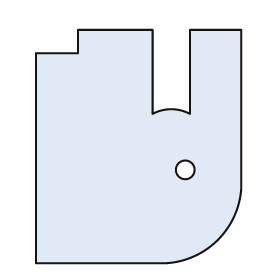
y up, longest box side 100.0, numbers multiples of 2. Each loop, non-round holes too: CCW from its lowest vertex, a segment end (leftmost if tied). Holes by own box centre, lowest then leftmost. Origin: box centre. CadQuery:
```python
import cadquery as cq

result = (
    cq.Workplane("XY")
    .moveTo(-44.0, -50.0)
    .lineTo(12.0, -50.0)
    .threePointArc((34.0, -40.0), (44.0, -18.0))
    .lineTo(44.0, 50.0)
    .lineTo(22.0, 50.0)
    .lineTo(22.0, 14.0)
    .threePointArc((14.0, 16.0), (6.0, 14.0))
    .lineTo(6.0, 50.0)
    .lineTo(-26.0, 50.0)
    .lineTo(-26.0, 40.0)
    .lineTo(-44.0, 40.0)
    .close()
    .moveTo(20.0, -10.0)
    .circle(4.0)
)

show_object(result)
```